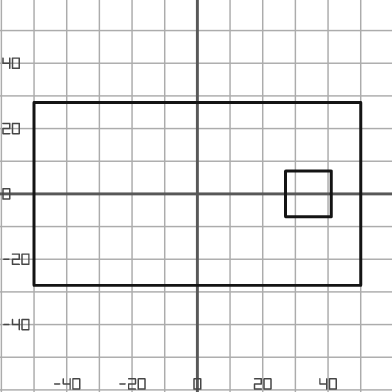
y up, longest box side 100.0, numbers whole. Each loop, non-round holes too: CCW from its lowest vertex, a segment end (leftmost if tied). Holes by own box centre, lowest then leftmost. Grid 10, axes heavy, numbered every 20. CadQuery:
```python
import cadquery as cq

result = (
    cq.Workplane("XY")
    .moveTo(-50.0, -28.0)
    .lineTo(50.0, -28.0)
    .lineTo(50.0, 28.0)
    .lineTo(-50.0, 28.0)
    .close()
    .moveTo(27.0, -7.0)
    .lineTo(41.0, -7.0)
    .lineTo(41.0, 7.0)
    .lineTo(27.0, 7.0)
    .close()
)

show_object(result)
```